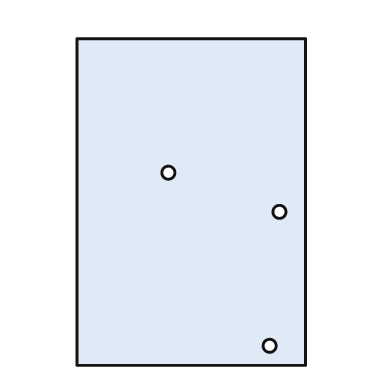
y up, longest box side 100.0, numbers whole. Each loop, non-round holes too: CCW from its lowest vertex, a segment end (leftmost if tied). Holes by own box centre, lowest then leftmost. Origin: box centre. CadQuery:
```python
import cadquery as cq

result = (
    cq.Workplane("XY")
    .moveTo(-35.0, -50.0)
    .lineTo(35.0, -50.0)
    .lineTo(35.0, 50.0)
    .lineTo(-35.0, 50.0)
    .close()
    .moveTo(24.0, -44.0)
    .circle(2.0)
    .moveTo(27.0, -3.0)
    .circle(2.0)
    .moveTo(-7.0, 9.0)
    .circle(2.0)
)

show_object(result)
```